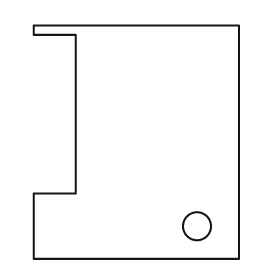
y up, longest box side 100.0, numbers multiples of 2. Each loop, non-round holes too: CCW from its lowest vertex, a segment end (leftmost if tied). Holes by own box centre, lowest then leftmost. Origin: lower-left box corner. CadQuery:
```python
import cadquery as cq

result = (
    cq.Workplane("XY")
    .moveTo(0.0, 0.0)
    .lineTo(88.0, 0.0)
    .lineTo(88.0, 100.0)
    .lineTo(0.0, 100.0)
    .lineTo(0.0, 96.0)
    .lineTo(18.0, 96.0)
    .lineTo(18.0, 28.0)
    .lineTo(0.0, 28.0)
    .close()
    .moveTo(70.0, 14.0)
    .circle(6.0)
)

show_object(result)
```